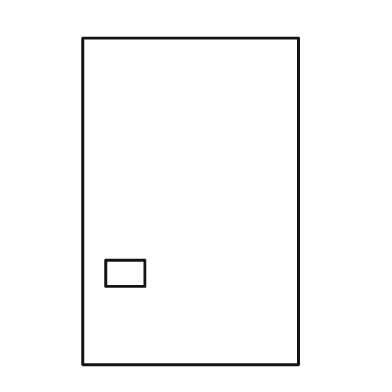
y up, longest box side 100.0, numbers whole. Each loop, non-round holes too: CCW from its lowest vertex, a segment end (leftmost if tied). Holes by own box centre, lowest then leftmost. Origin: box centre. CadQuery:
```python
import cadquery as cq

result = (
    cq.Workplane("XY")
    .moveTo(-33.0, -50.0)
    .lineTo(33.0, -50.0)
    .lineTo(33.0, 50.0)
    .lineTo(-33.0, 50.0)
    .close()
    .moveTo(-26.0, -26.0)
    .lineTo(-14.0, -26.0)
    .lineTo(-14.0, -18.0)
    .lineTo(-26.0, -18.0)
    .close()
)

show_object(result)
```